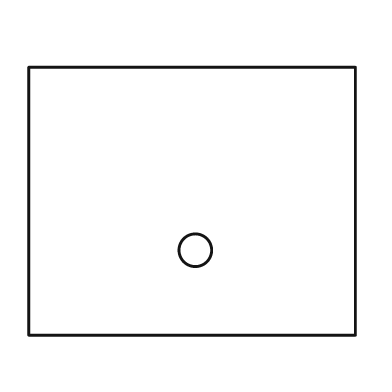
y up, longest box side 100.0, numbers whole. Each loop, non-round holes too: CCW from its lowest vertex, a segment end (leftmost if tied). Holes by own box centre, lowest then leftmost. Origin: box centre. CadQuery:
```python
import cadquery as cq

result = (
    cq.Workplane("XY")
    .moveTo(-50.0, -41.0)
    .lineTo(50.0, -41.0)
    .lineTo(50.0, 41.0)
    .lineTo(-50.0, 41.0)
    .close()
    .moveTo(1.0, -15.0)
    .circle(5.0)
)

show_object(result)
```